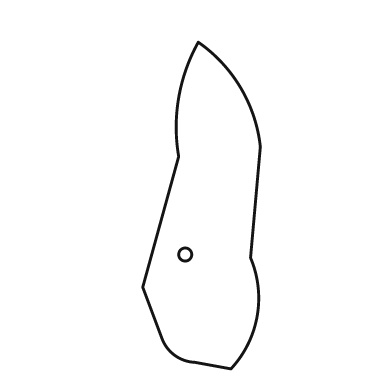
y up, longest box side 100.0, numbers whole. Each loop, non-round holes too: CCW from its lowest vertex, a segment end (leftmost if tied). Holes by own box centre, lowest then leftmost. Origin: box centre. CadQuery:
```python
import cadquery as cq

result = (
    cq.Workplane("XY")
    .moveTo(9.0, -50.0)
    .threePointArc((17.0, -34.0), (15.0, -16.0))
    .lineTo(18.0, 18.0)
    .threePointArc((12.0, 36.0), (-1.0, 50.0))
    .threePointArc((-7.0, 33.0), (-7.0, 15.0))
    .lineTo(-18.0, -25.0)
    .lineTo(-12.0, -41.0)
    .threePointArc((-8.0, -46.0), (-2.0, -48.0))
    .close()
    .moveTo(-5.0, -15.0)
    .circle(2.0)
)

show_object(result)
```